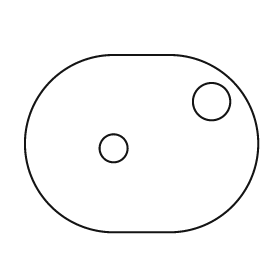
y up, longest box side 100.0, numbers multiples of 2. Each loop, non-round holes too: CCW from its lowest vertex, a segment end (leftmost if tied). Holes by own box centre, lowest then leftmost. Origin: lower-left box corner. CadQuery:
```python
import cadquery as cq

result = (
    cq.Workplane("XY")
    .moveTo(38.0, 0.0)
    .lineTo(62.0, 0.0)
    .threePointArc((100.0, 38.0), (62.0, 76.0))
    .lineTo(38.0, 76.0)
    .threePointArc((0.0, 38.0), (38.0, 0.0))
    .close()
    .moveTo(38.0, 36.0)
    .circle(6.0)
    .moveTo(80.0, 56.0)
    .circle(8.0)
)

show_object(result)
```